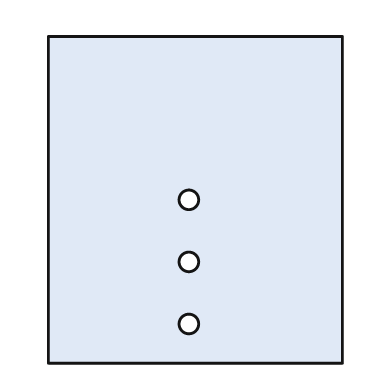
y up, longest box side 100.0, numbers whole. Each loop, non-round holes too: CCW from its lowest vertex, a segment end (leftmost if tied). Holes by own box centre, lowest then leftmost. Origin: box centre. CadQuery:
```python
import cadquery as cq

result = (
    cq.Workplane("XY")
    .moveTo(-45.0, -50.0)
    .lineTo(45.0, -50.0)
    .lineTo(45.0, 50.0)
    .lineTo(-45.0, 50.0)
    .close()
    .moveTo(-2.0, -38.0)
    .circle(3.0)
    .moveTo(-2.0, -19.0)
    .circle(3.0)
    .moveTo(-2.0, 0.0)
    .circle(3.0)
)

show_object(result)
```